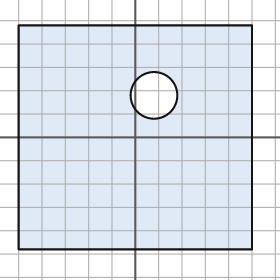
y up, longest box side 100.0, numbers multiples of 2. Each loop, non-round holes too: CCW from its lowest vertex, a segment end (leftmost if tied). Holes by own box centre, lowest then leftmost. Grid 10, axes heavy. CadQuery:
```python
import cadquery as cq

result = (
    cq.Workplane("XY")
    .moveTo(-50.0, -48.0)
    .lineTo(50.0, -48.0)
    .lineTo(50.0, 48.0)
    .lineTo(-50.0, 48.0)
    .close()
    .moveTo(8.0, 18.0)
    .circle(10.0)
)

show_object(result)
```